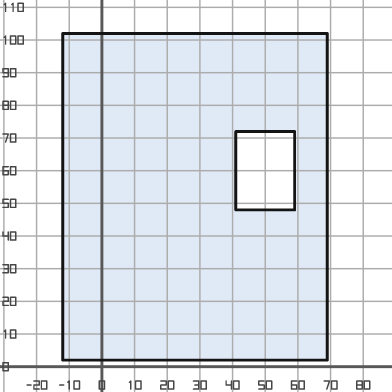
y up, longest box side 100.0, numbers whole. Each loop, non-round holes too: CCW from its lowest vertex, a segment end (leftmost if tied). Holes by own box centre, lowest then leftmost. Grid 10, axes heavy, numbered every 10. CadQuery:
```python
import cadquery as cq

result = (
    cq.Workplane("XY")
    .moveTo(-12.0, 2.0)
    .lineTo(69.0, 2.0)
    .lineTo(69.0, 102.0)
    .lineTo(-12.0, 102.0)
    .close()
    .moveTo(41.0, 48.0)
    .lineTo(59.0, 48.0)
    .lineTo(59.0, 72.0)
    .lineTo(41.0, 72.0)
    .close()
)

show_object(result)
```